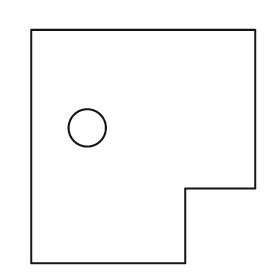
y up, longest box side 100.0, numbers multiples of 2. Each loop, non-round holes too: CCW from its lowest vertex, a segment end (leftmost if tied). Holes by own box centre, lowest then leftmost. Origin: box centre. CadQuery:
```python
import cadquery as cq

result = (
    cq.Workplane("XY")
    .moveTo(-48.0, -50.0)
    .lineTo(18.0, -50.0)
    .lineTo(18.0, -18.0)
    .lineTo(48.0, -18.0)
    .lineTo(48.0, 50.0)
    .lineTo(-48.0, 50.0)
    .close()
    .moveTo(-24.0, 8.0)
    .circle(8.0)
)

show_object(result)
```